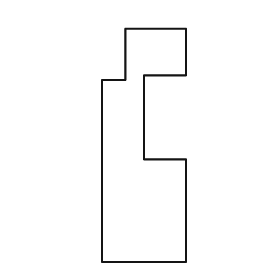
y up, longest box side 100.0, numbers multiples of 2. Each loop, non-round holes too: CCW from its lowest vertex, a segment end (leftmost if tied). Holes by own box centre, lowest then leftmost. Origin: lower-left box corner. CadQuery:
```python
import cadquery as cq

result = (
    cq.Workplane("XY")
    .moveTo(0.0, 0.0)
    .lineTo(36.0, 0.0)
    .lineTo(36.0, 44.0)
    .lineTo(18.0, 44.0)
    .lineTo(18.0, 80.0)
    .lineTo(36.0, 80.0)
    .lineTo(36.0, 100.0)
    .lineTo(10.0, 100.0)
    .lineTo(10.0, 78.0)
    .lineTo(0.0, 78.0)
    .close()
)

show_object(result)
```